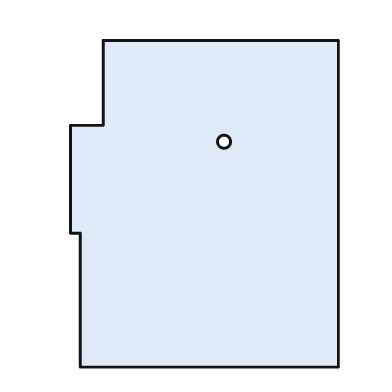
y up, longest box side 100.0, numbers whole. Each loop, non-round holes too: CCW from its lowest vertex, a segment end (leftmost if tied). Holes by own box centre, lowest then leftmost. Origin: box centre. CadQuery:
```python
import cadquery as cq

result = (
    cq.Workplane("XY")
    .moveTo(-38.0, -50.0)
    .lineTo(41.0, -50.0)
    .lineTo(41.0, 50.0)
    .lineTo(-31.0, 50.0)
    .lineTo(-31.0, 24.0)
    .lineTo(-41.0, 24.0)
    .lineTo(-41.0, -9.0)
    .lineTo(-38.0, -9.0)
    .close()
    .moveTo(6.0, 19.0)
    .circle(2.0)
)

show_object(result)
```